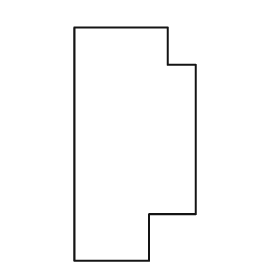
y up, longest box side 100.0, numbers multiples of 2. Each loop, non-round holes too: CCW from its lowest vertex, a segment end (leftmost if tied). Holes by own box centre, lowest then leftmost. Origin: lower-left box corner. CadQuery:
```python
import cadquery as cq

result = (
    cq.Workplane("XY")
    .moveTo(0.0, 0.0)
    .lineTo(32.0, 0.0)
    .lineTo(32.0, 20.0)
    .lineTo(52.0, 20.0)
    .lineTo(52.0, 84.0)
    .lineTo(40.0, 84.0)
    .lineTo(40.0, 100.0)
    .lineTo(0.0, 100.0)
    .close()
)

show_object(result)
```